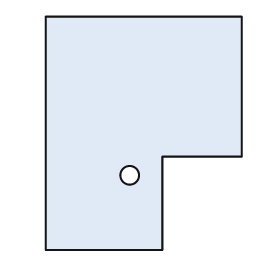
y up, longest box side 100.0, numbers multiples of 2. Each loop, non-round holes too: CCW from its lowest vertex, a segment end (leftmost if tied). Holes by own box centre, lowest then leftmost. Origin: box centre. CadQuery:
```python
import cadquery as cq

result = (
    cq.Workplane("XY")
    .moveTo(-42.0, -50.0)
    .lineTo(8.0, -50.0)
    .lineTo(8.0, -10.0)
    .lineTo(42.0, -10.0)
    .lineTo(42.0, 50.0)
    .lineTo(-42.0, 50.0)
    .close()
    .moveTo(-6.0, -18.0)
    .circle(4.0)
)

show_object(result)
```